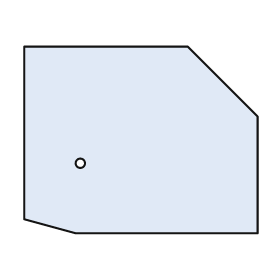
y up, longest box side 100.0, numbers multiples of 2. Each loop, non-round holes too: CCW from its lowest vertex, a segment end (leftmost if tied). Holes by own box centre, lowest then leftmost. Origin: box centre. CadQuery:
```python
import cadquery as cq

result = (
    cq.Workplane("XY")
    .moveTo(-28.0, -40.0)
    .lineTo(50.0, -40.0)
    .lineTo(50.0, 10.0)
    .lineTo(20.0, 40.0)
    .lineTo(-50.0, 40.0)
    .lineTo(-50.0, -34.0)
    .close()
    .moveTo(-26.0, -10.0)
    .circle(2.0)
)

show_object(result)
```